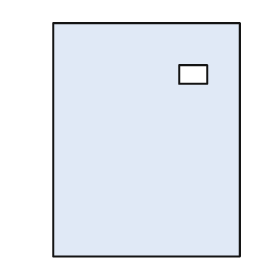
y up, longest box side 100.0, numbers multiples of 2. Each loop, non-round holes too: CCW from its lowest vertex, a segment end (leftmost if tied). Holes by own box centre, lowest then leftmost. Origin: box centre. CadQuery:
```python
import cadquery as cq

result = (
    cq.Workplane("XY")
    .moveTo(-40.0, -50.0)
    .lineTo(40.0, -50.0)
    .lineTo(40.0, 50.0)
    .lineTo(-40.0, 50.0)
    .close()
    .moveTo(14.0, 24.0)
    .lineTo(26.0, 24.0)
    .lineTo(26.0, 32.0)
    .lineTo(14.0, 32.0)
    .close()
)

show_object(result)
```